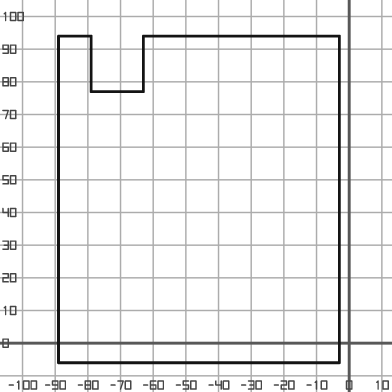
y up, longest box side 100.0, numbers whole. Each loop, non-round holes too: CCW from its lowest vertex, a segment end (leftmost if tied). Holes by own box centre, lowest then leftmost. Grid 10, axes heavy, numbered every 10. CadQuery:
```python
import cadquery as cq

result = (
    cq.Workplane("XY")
    .moveTo(-89.0, -6.0)
    .lineTo(-3.0, -6.0)
    .lineTo(-3.0, 94.0)
    .lineTo(-63.0, 94.0)
    .lineTo(-63.0, 77.0)
    .lineTo(-79.0, 77.0)
    .lineTo(-79.0, 94.0)
    .lineTo(-89.0, 94.0)
    .close()
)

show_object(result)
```